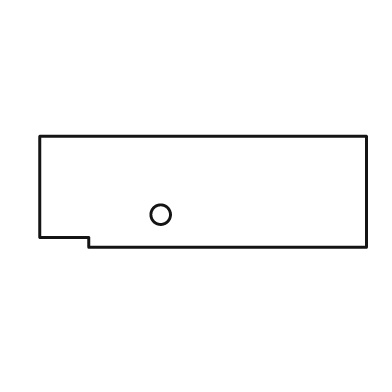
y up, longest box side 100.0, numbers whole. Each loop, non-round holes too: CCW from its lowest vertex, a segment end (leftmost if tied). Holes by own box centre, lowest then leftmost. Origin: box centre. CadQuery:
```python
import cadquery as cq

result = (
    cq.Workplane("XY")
    .moveTo(-35.0, -17.0)
    .lineTo(50.0, -17.0)
    .lineTo(50.0, 17.0)
    .lineTo(-50.0, 17.0)
    .lineTo(-50.0, -14.0)
    .lineTo(-35.0, -14.0)
    .close()
    .moveTo(-13.0, -7.0)
    .circle(3.0)
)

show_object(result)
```